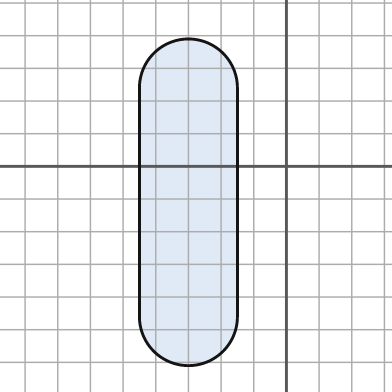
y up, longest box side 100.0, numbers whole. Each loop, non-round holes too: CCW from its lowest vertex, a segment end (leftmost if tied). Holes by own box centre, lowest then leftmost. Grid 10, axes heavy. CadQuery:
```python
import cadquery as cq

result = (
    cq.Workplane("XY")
    .moveTo(-45.0, -46.0)
    .threePointArc((-30.0, -61.0), (-15.0, -46.0))
    .lineTo(-15.0, 24.0)
    .threePointArc((-30.0, 39.0), (-45.0, 24.0))
    .close()
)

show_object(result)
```